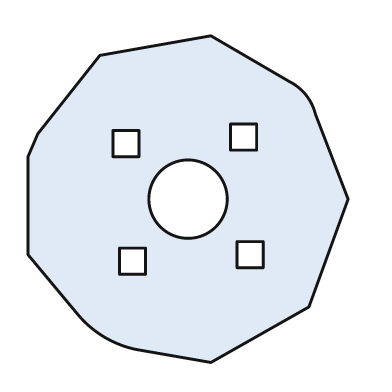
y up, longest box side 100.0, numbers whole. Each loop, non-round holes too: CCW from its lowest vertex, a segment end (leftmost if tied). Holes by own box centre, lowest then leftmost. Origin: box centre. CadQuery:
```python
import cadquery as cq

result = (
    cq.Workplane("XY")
    .moveTo(7.0, -50.0)
    .lineTo(37.0, -33.0)
    .lineTo(49.0, 0.0)
    .lineTo(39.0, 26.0)
    .threePointArc((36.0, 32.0), (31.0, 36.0))
    .lineTo(7.0, 50.0)
    .lineTo(-27.0, 44.0)
    .lineTo(-46.0, 20.0)
    .lineTo(-49.0, 13.0)
    .lineTo(-49.0, -17.0)
    .lineTo(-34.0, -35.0)
    .threePointArc((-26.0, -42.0), (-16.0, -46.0))
    .close()
    .moveTo(-21.0, -23.0)
    .lineTo(-13.0, -23.0)
    .lineTo(-13.0, -15.0)
    .lineTo(-21.0, -15.0)
    .close()
    .moveTo(15.0, -21.0)
    .lineTo(23.0, -21.0)
    .lineTo(23.0, -13.0)
    .lineTo(15.0, -13.0)
    .close()
    .moveTo(0.0, 0.0)
    .circle(12.0)
    .moveTo(-23.0, 13.0)
    .lineTo(-15.0, 13.0)
    .lineTo(-15.0, 21.0)
    .lineTo(-23.0, 21.0)
    .close()
    .moveTo(13.0, 15.0)
    .lineTo(21.0, 15.0)
    .lineTo(21.0, 23.0)
    .lineTo(13.0, 23.0)
    .close()
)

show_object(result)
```